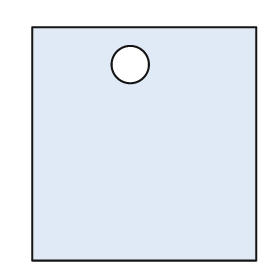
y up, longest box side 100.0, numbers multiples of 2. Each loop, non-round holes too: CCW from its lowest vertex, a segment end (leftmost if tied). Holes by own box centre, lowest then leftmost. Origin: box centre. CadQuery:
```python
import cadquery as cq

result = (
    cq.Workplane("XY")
    .moveTo(-48.0, -50.0)
    .lineTo(48.0, -50.0)
    .lineTo(48.0, 50.0)
    .lineTo(-48.0, 50.0)
    .close()
    .moveTo(-6.0, 34.0)
    .circle(8.0)
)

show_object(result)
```